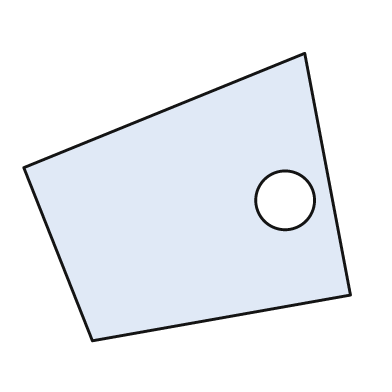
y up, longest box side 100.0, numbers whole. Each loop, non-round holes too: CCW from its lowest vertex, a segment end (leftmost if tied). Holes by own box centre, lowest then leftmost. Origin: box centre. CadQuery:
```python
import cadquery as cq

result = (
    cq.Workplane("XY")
    .moveTo(-29.0, -44.0)
    .lineTo(50.0, -30.0)
    .lineTo(36.0, 44.0)
    .lineTo(-50.0, 9.0)
    .close()
    .moveTo(30.0, -1.0)
    .circle(9.0)
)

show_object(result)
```